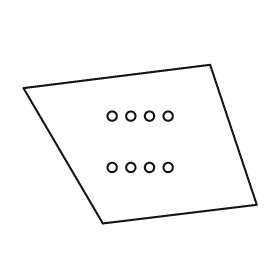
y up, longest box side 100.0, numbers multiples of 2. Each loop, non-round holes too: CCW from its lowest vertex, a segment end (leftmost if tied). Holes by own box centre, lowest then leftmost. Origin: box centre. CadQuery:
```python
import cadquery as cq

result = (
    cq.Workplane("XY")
    .moveTo(-16.0, -34.0)
    .lineTo(50.0, -26.0)
    .lineTo(30.0, 34.0)
    .lineTo(-50.0, 24.0)
    .close()
    .moveTo(-12.0, -10.0)
    .circle(2.0)
    .moveTo(-4.0, -10.0)
    .circle(2.0)
    .moveTo(4.0, -10.0)
    .circle(2.0)
    .moveTo(12.0, -10.0)
    .circle(2.0)
    .moveTo(-12.0, 12.0)
    .circle(2.0)
    .moveTo(-4.0, 12.0)
    .circle(2.0)
    .moveTo(4.0, 12.0)
    .circle(2.0)
    .moveTo(12.0, 12.0)
    .circle(2.0)
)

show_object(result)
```